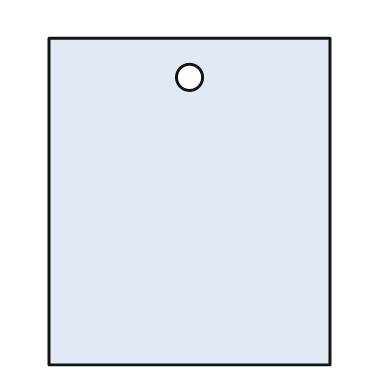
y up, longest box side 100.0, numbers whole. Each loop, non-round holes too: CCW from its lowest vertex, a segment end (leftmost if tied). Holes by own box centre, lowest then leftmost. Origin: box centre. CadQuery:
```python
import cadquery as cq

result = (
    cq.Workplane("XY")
    .moveTo(-43.0, -50.0)
    .lineTo(43.0, -50.0)
    .lineTo(43.0, 50.0)
    .lineTo(-43.0, 50.0)
    .close()
    .moveTo(0.0, 38.0)
    .circle(4.0)
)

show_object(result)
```